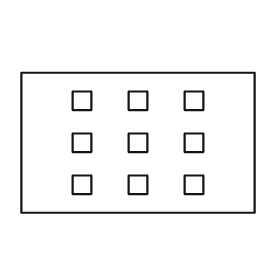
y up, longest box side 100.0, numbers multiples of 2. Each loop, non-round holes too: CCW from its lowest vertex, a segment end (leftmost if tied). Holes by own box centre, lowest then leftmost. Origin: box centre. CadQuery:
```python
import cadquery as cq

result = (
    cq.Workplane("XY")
    .moveTo(-50.0, -30.0)
    .lineTo(50.0, -30.0)
    .lineTo(50.0, 30.0)
    .lineTo(-50.0, 30.0)
    .close()
    .moveTo(-28.0, -22.0)
    .lineTo(-20.0, -22.0)
    .lineTo(-20.0, -14.0)
    .lineTo(-28.0, -14.0)
    .close()
    .moveTo(-4.0, -22.0)
    .lineTo(4.0, -22.0)
    .lineTo(4.0, -14.0)
    .lineTo(-4.0, -14.0)
    .close()
    .moveTo(20.0, -22.0)
    .lineTo(28.0, -22.0)
    .lineTo(28.0, -14.0)
    .lineTo(20.0, -14.0)
    .close()
    .moveTo(-28.0, -4.0)
    .lineTo(-20.0, -4.0)
    .lineTo(-20.0, 4.0)
    .lineTo(-28.0, 4.0)
    .close()
    .moveTo(-4.0, -4.0)
    .lineTo(4.0, -4.0)
    .lineTo(4.0, 4.0)
    .lineTo(-4.0, 4.0)
    .close()
    .moveTo(20.0, -4.0)
    .lineTo(28.0, -4.0)
    .lineTo(28.0, 4.0)
    .lineTo(20.0, 4.0)
    .close()
    .moveTo(-28.0, 14.0)
    .lineTo(-20.0, 14.0)
    .lineTo(-20.0, 22.0)
    .lineTo(-28.0, 22.0)
    .close()
    .moveTo(-4.0, 14.0)
    .lineTo(4.0, 14.0)
    .lineTo(4.0, 22.0)
    .lineTo(-4.0, 22.0)
    .close()
    .moveTo(20.0, 14.0)
    .lineTo(28.0, 14.0)
    .lineTo(28.0, 22.0)
    .lineTo(20.0, 22.0)
    .close()
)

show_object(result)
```